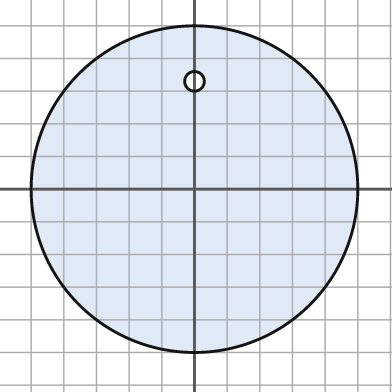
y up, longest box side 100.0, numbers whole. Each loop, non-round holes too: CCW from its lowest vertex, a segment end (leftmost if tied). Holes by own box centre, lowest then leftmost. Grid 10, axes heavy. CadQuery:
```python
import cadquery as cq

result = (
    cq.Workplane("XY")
    .moveTo(0.0, 0.0)
    .circle(50.0)
    .moveTo(0.0, 33.0)
    .circle(3.0)
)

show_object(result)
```